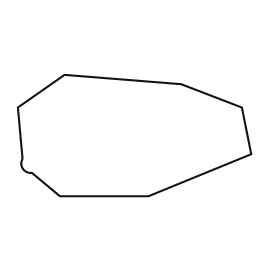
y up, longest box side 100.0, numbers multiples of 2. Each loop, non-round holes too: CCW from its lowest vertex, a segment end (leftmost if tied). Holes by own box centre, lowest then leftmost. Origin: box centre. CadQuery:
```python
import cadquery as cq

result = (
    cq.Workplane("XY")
    .moveTo(-32.0, -26.0)
    .lineTo(6.0, -26.0)
    .lineTo(50.0, -8.0)
    .lineTo(46.0, 12.0)
    .lineTo(20.0, 22.0)
    .lineTo(-30.0, 26.0)
    .lineTo(-50.0, 12.0)
    .lineTo(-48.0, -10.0)
    .threePointArc((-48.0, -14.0), (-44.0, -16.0))
    .close()
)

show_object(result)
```